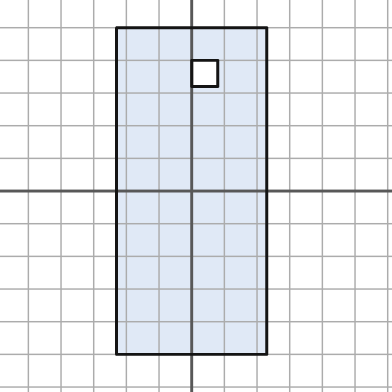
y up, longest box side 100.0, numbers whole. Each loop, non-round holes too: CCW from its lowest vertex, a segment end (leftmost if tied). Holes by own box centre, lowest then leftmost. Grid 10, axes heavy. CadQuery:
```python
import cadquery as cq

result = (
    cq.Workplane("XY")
    .moveTo(-23.0, -50.0)
    .lineTo(23.0, -50.0)
    .lineTo(23.0, 50.0)
    .lineTo(-23.0, 50.0)
    .close()
    .moveTo(0.0, 32.0)
    .lineTo(8.0, 32.0)
    .lineTo(8.0, 40.0)
    .lineTo(0.0, 40.0)
    .close()
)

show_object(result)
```